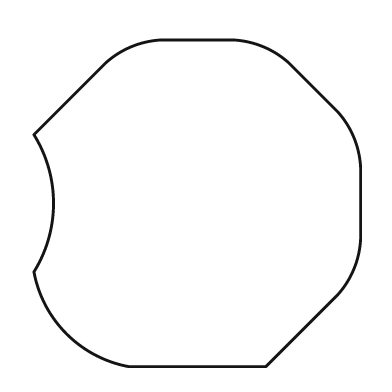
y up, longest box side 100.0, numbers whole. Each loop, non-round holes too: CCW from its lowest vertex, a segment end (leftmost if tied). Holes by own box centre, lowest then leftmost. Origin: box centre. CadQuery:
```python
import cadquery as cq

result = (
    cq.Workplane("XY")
    .moveTo(-21.0, -50.0)
    .lineTo(21.0, -50.0)
    .lineTo(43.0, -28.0)
    .threePointArc((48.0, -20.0), (50.0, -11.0))
    .lineTo(50.0, 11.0)
    .threePointArc((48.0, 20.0), (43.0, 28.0))
    .lineTo(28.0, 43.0)
    .threePointArc((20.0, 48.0), (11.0, 50.0))
    .lineTo(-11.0, 50.0)
    .threePointArc((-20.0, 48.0), (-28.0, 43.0))
    .lineTo(-50.0, 21.0)
    .threePointArc((-44.0, 0.0), (-50.0, -21.0))
    .threePointArc((-40.0, -40.0), (-21.0, -50.0))
    .close()
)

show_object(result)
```